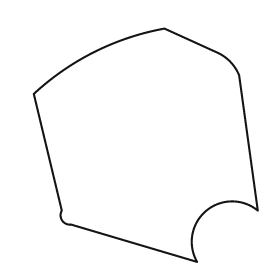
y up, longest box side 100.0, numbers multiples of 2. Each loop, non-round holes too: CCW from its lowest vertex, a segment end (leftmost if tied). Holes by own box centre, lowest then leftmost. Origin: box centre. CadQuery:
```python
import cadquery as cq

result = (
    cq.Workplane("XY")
    .moveTo(22.0, -50.0)
    .threePointArc((26.0, -28.0), (48.0, -28.0))
    .lineTo(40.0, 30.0)
    .threePointArc((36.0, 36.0), (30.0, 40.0))
    .lineTo(8.0, 50.0)
    .threePointArc((-22.0, 40.0), (-48.0, 22.0))
    .lineTo(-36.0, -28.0)
    .threePointArc((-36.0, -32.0), (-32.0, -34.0))
    .close()
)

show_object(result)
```